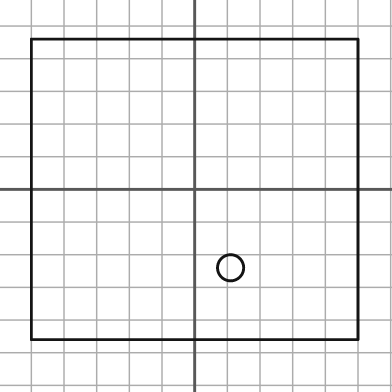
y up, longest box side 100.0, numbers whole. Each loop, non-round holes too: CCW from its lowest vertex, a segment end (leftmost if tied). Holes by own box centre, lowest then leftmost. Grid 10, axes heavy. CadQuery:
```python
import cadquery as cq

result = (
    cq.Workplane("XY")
    .moveTo(-50.0, -46.0)
    .lineTo(50.0, -46.0)
    .lineTo(50.0, 46.0)
    .lineTo(-50.0, 46.0)
    .close()
    .moveTo(11.0, -24.0)
    .circle(4.0)
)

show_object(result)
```